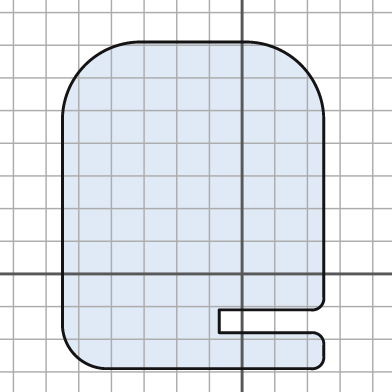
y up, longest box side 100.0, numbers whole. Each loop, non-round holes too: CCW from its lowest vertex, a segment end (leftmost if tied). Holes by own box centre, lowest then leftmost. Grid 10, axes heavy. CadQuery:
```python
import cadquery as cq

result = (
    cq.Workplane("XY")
    .moveTo(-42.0, -29.0)
    .lineTo(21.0, -29.0)
    .threePointArc((24.0, -28.0), (25.0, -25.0))
    .lineTo(25.0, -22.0)
    .threePointArc((24.0, -19.0), (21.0, -18.0))
    .lineTo(-7.0, -18.0)
    .lineTo(-7.0, -11.0)
    .lineTo(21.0, -11.0)
    .threePointArc((24.0, -10.0), (25.0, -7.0))
    .lineTo(25.0, 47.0)
    .threePointArc((18.0, 64.0), (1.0, 71.0))
    .lineTo(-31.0, 71.0)
    .threePointArc((-48.0, 64.0), (-55.0, 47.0))
    .lineTo(-55.0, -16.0)
    .threePointArc((-51.0, -25.0), (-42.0, -29.0))
    .close()
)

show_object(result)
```